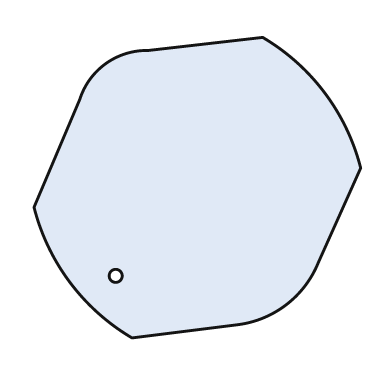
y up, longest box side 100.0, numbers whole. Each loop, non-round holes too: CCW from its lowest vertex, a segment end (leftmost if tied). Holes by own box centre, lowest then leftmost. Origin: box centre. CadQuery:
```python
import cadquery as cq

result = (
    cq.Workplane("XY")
    .moveTo(-20.0, -46.0)
    .lineTo(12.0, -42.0)
    .threePointArc((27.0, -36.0), (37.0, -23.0))
    .lineTo(50.0, 6.0)
    .threePointArc((39.0, 29.0), (20.0, 46.0))
    .lineTo(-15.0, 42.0)
    .threePointArc((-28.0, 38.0), (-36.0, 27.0))
    .lineTo(-50.0, -6.0)
    .threePointArc((-39.0, -29.0), (-20.0, -46.0))
    .close()
    .moveTo(-25.0, -27.0)
    .circle(2.0)
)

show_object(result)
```